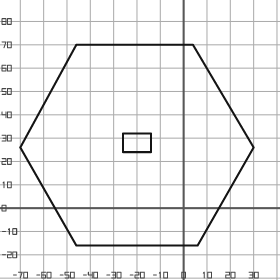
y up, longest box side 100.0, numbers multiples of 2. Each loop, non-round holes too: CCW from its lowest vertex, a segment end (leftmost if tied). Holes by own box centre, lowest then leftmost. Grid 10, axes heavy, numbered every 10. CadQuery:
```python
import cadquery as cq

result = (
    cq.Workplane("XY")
    .moveTo(-46.0, -16.0)
    .lineTo(6.0, -16.0)
    .lineTo(30.0, 26.0)
    .lineTo(4.0, 70.0)
    .lineTo(-46.0, 70.0)
    .lineTo(-70.0, 26.0)
    .close()
    .moveTo(-26.0, 24.0)
    .lineTo(-14.0, 24.0)
    .lineTo(-14.0, 32.0)
    .lineTo(-26.0, 32.0)
    .close()
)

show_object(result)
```